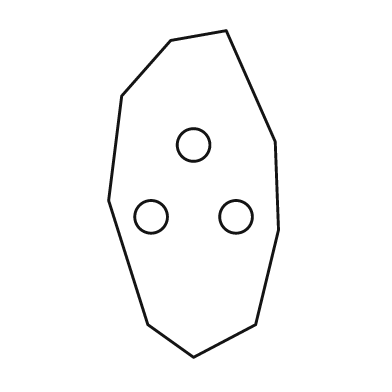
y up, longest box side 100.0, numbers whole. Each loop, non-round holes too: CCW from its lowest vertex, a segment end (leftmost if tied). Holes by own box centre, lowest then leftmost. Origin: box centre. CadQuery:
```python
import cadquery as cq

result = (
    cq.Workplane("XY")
    .moveTo(0.0, -50.0)
    .lineTo(19.0, -40.0)
    .lineTo(26.0, -11.0)
    .lineTo(25.0, 16.0)
    .lineTo(10.0, 50.0)
    .lineTo(-7.0, 47.0)
    .lineTo(-22.0, 30.0)
    .lineTo(-26.0, -2.0)
    .lineTo(-14.0, -40.0)
    .close()
    .moveTo(-13.0, -7.0)
    .circle(5.0)
    .moveTo(13.0, -7.0)
    .circle(5.0)
    .moveTo(0.0, 15.0)
    .circle(5.0)
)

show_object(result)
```